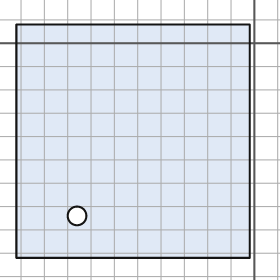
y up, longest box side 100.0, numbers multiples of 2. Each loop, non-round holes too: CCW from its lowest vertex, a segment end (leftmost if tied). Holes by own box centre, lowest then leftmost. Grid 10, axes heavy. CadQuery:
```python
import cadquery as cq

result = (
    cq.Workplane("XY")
    .moveTo(-102.0, -92.0)
    .lineTo(-2.0, -92.0)
    .lineTo(-2.0, 8.0)
    .lineTo(-102.0, 8.0)
    .close()
    .moveTo(-76.0, -74.0)
    .circle(4.0)
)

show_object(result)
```